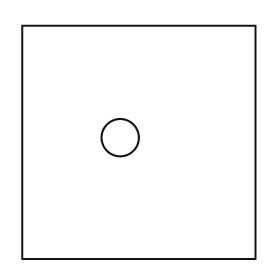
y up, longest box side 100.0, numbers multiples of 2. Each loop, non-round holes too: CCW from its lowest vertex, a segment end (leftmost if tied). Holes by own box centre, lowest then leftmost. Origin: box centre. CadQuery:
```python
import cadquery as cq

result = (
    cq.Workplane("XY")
    .moveTo(-50.0, -50.0)
    .lineTo(50.0, -50.0)
    .lineTo(50.0, 50.0)
    .lineTo(-50.0, 50.0)
    .close()
    .moveTo(-8.0, 2.0)
    .circle(8.0)
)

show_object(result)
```